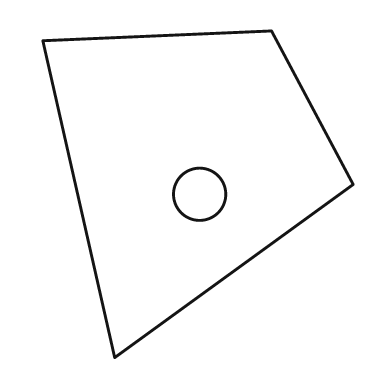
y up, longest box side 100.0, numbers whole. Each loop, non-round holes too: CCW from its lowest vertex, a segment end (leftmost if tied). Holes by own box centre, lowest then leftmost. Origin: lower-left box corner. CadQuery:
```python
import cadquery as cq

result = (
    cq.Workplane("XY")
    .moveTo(22.0, 0.0)
    .lineTo(95.0, 53.0)
    .lineTo(70.0, 100.0)
    .lineTo(0.0, 97.0)
    .close()
    .moveTo(48.0, 50.0)
    .circle(8.0)
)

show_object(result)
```